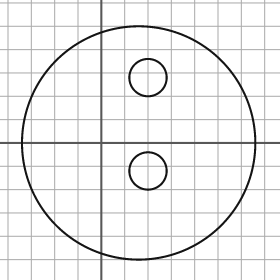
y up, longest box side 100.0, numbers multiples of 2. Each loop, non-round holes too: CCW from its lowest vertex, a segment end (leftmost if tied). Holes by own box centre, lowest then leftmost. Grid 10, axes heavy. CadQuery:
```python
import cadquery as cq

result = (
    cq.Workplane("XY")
    .moveTo(16.0, 0.0)
    .circle(50.0)
    .moveTo(20.0, -12.0)
    .circle(8.0)
    .moveTo(20.0, 28.0)
    .circle(8.0)
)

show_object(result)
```